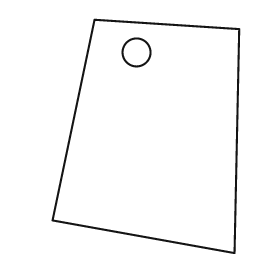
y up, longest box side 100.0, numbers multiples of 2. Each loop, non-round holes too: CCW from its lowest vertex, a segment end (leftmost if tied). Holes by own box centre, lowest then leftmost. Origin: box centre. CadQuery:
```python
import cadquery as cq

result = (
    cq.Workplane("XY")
    .moveTo(38.0, -50.0)
    .lineTo(40.0, 46.0)
    .lineTo(-22.0, 50.0)
    .lineTo(-40.0, -36.0)
    .close()
    .moveTo(-4.0, 36.0)
    .circle(6.0)
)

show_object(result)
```